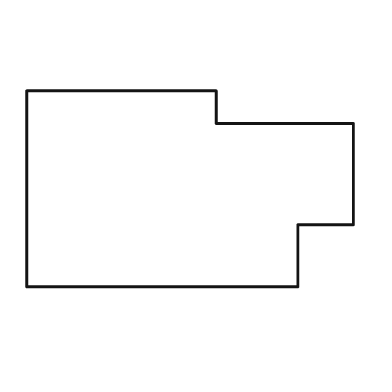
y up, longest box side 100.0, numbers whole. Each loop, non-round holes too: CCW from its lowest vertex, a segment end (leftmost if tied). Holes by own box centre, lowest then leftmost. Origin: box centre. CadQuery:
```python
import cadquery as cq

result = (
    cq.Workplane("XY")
    .moveTo(-50.0, -30.0)
    .lineTo(33.0, -30.0)
    .lineTo(33.0, -11.0)
    .lineTo(50.0, -11.0)
    .lineTo(50.0, 20.0)
    .lineTo(8.0, 20.0)
    .lineTo(8.0, 30.0)
    .lineTo(-50.0, 30.0)
    .close()
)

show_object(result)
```